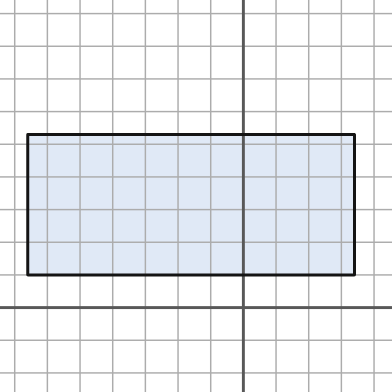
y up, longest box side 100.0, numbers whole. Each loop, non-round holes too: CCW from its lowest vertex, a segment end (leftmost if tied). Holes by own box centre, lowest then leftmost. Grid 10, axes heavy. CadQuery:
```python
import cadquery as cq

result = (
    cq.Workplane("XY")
    .moveTo(-66.0, 10.0)
    .lineTo(34.0, 10.0)
    .lineTo(34.0, 53.0)
    .lineTo(-66.0, 53.0)
    .close()
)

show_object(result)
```